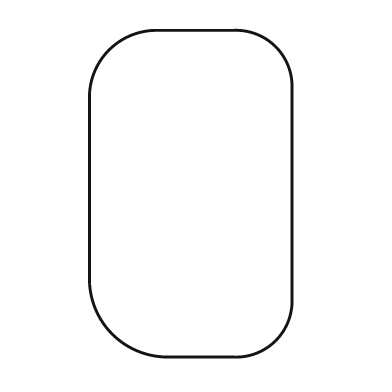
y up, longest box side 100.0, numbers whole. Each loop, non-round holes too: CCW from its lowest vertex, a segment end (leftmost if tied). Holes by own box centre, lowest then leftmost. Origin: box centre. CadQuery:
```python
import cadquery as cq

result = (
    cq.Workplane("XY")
    .moveTo(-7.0, -50.0)
    .lineTo(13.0, -50.0)
    .threePointArc((26.0, -45.0), (31.0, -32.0))
    .lineTo(31.0, 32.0)
    .threePointArc((26.0, 45.0), (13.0, 50.0))
    .lineTo(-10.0, 50.0)
    .threePointArc((-25.0, 44.0), (-31.0, 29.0))
    .lineTo(-31.0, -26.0)
    .threePointArc((-24.0, -43.0), (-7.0, -50.0))
    .close()
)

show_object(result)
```